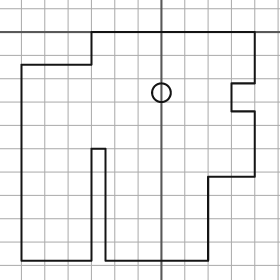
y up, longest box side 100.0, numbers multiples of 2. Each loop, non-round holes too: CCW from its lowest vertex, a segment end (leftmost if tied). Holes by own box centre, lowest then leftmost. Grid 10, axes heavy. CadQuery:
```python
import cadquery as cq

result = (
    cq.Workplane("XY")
    .moveTo(-60.0, -98.0)
    .lineTo(-30.0, -98.0)
    .lineTo(-30.0, -50.0)
    .lineTo(-24.0, -50.0)
    .lineTo(-24.0, -98.0)
    .lineTo(20.0, -98.0)
    .lineTo(20.0, -62.0)
    .lineTo(40.0, -62.0)
    .lineTo(40.0, -34.0)
    .lineTo(30.0, -34.0)
    .lineTo(30.0, -22.0)
    .lineTo(40.0, -22.0)
    .lineTo(40.0, 0.0)
    .lineTo(-30.0, 0.0)
    .lineTo(-30.0, -14.0)
    .lineTo(-60.0, -14.0)
    .close()
    .moveTo(0.0, -26.0)
    .circle(4.0)
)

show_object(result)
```